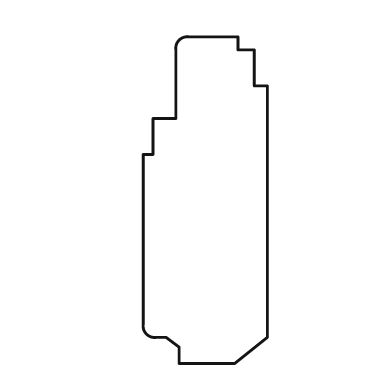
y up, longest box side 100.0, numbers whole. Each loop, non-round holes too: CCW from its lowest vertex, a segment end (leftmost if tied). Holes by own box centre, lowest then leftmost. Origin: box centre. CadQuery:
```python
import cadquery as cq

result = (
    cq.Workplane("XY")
    .moveTo(-8.0, -50.0)
    .lineTo(9.0, -50.0)
    .lineTo(19.0, -42.0)
    .lineTo(19.0, 35.0)
    .lineTo(15.0, 35.0)
    .lineTo(15.0, 46.0)
    .lineTo(10.0, 46.0)
    .lineTo(10.0, 50.0)
    .lineTo(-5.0, 50.0)
    .threePointArc((-8.0, 49.0), (-9.0, 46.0))
    .lineTo(-9.0, 25.0)
    .lineTo(-16.0, 25.0)
    .lineTo(-16.0, 14.0)
    .lineTo(-19.0, 14.0)
    .lineTo(-19.0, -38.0)
    .threePointArc((-18.0, -41.0), (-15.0, -42.0))
    .lineTo(-12.0, -42.0)
    .lineTo(-8.0, -45.0)
    .close()
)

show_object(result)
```